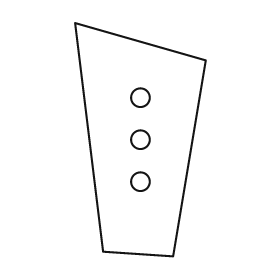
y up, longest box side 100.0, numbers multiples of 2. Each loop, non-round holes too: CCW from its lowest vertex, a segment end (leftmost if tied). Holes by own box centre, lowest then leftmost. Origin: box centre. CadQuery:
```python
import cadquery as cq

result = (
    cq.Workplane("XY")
    .moveTo(14.0, -50.0)
    .lineTo(28.0, 34.0)
    .lineTo(-28.0, 50.0)
    .lineTo(-16.0, -48.0)
    .close()
    .moveTo(0.0, -18.0)
    .circle(4.0)
    .moveTo(0.0, 0.0)
    .circle(4.0)
    .moveTo(0.0, 18.0)
    .circle(4.0)
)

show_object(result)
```